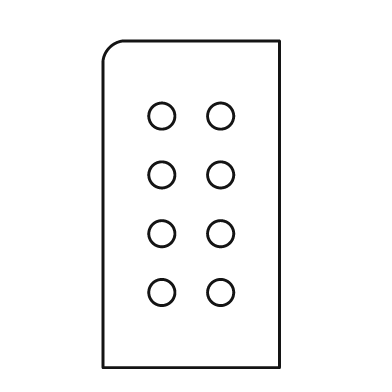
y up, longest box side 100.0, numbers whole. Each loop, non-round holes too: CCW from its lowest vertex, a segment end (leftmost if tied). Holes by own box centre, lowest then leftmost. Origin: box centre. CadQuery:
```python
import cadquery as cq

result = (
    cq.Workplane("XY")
    .moveTo(-27.0, -50.0)
    .lineTo(27.0, -50.0)
    .lineTo(27.0, 50.0)
    .lineTo(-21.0, 50.0)
    .threePointArc((-25.0, 48.0), (-27.0, 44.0))
    .close()
    .moveTo(-9.0, -27.0)
    .circle(4.0)
    .moveTo(9.0, -27.0)
    .circle(4.0)
    .moveTo(-9.0, -9.0)
    .circle(4.0)
    .moveTo(9.0, -9.0)
    .circle(4.0)
    .moveTo(-9.0, 9.0)
    .circle(4.0)
    .moveTo(9.0, 9.0)
    .circle(4.0)
    .moveTo(-9.0, 27.0)
    .circle(4.0)
    .moveTo(9.0, 27.0)
    .circle(4.0)
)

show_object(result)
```